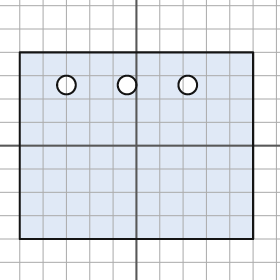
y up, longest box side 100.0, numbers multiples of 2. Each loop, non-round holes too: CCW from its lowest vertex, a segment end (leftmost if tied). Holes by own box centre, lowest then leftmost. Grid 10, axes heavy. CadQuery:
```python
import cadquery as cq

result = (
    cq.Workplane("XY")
    .moveTo(-50.0, -40.0)
    .lineTo(50.0, -40.0)
    .lineTo(50.0, 40.0)
    .lineTo(-50.0, 40.0)
    .close()
    .moveTo(-30.0, 26.0)
    .circle(4.0)
    .moveTo(-4.0, 26.0)
    .circle(4.0)
    .moveTo(22.0, 26.0)
    .circle(4.0)
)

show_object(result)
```